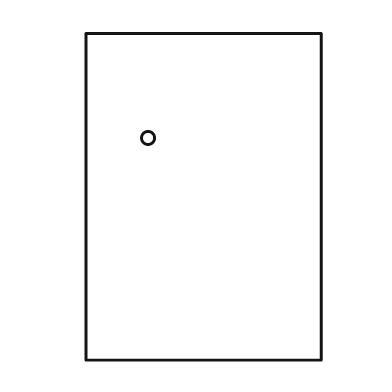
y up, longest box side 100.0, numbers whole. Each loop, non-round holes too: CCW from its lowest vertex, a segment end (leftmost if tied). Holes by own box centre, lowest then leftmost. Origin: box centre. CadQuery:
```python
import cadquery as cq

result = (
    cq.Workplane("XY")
    .moveTo(-36.0, -50.0)
    .lineTo(36.0, -50.0)
    .lineTo(36.0, 50.0)
    .lineTo(-36.0, 50.0)
    .close()
    .moveTo(-17.0, 18.0)
    .circle(2.0)
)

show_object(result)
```